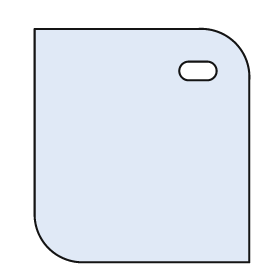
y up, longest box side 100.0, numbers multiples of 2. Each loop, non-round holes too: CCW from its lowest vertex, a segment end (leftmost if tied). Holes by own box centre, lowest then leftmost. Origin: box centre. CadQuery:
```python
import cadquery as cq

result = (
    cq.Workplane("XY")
    .moveTo(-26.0, -50.0)
    .lineTo(46.0, -50.0)
    .lineTo(46.0, 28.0)
    .threePointArc((40.0, 44.0), (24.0, 50.0))
    .lineTo(-46.0, 50.0)
    .lineTo(-46.0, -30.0)
    .threePointArc((-40.0, -44.0), (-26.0, -50.0))
    .close()
    .moveTo(20.0, 28.0)
    .lineTo(28.0, 28.0)
    .threePointArc((32.0, 32.0), (28.0, 36.0))
    .lineTo(20.0, 36.0)
    .threePointArc((16.0, 32.0), (20.0, 28.0))
    .close()
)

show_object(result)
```